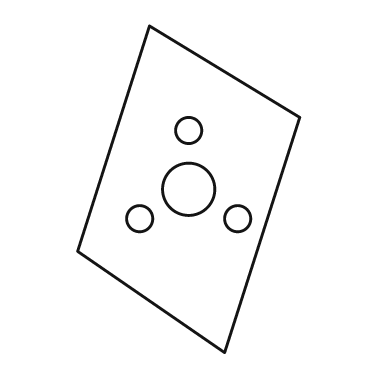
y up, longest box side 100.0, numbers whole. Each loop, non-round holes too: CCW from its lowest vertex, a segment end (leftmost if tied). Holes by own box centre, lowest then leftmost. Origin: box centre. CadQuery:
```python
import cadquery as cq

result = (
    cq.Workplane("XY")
    .moveTo(11.0, -50.0)
    .lineTo(34.0, 22.0)
    .lineTo(-12.0, 50.0)
    .lineTo(-34.0, -19.0)
    .close()
    .moveTo(-15.0, -9.0)
    .circle(4.0)
    .moveTo(15.0, -9.0)
    .circle(4.0)
    .moveTo(0.0, 0.0)
    .circle(8.0)
    .moveTo(0.0, 18.0)
    .circle(4.0)
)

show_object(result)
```